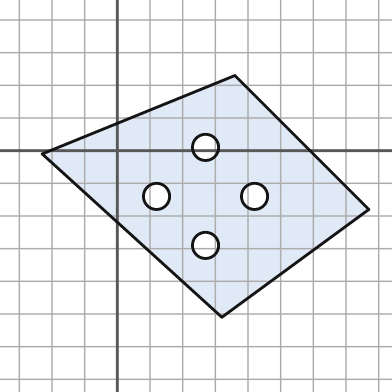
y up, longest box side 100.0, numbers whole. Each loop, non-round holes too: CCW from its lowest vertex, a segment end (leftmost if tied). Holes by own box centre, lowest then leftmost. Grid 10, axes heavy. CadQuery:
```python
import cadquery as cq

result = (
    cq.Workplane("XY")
    .moveTo(32.0, -51.0)
    .lineTo(77.0, -18.0)
    .lineTo(36.0, 23.0)
    .lineTo(-23.0, -1.0)
    .close()
    .moveTo(27.0, -29.0)
    .circle(4.0)
    .moveTo(12.0, -14.0)
    .circle(4.0)
    .moveTo(42.0, -14.0)
    .circle(4.0)
    .moveTo(27.0, 1.0)
    .circle(4.0)
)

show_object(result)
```